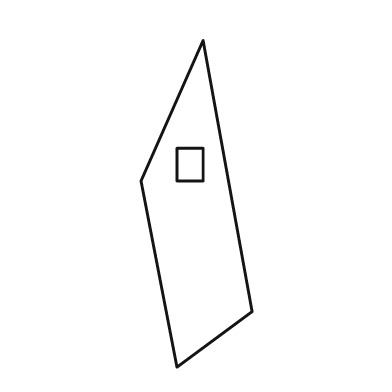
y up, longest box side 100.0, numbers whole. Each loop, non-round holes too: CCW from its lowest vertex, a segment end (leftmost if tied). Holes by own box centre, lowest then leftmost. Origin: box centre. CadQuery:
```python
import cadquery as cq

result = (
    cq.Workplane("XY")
    .moveTo(-6.0, -50.0)
    .lineTo(17.0, -33.0)
    .lineTo(2.0, 50.0)
    .lineTo(-17.0, 7.0)
    .close()
    .moveTo(-6.0, 7.0)
    .lineTo(2.0, 7.0)
    .lineTo(2.0, 17.0)
    .lineTo(-6.0, 17.0)
    .close()
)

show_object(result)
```